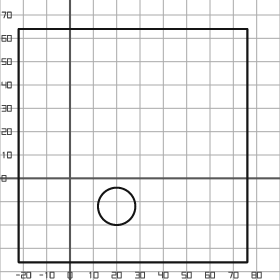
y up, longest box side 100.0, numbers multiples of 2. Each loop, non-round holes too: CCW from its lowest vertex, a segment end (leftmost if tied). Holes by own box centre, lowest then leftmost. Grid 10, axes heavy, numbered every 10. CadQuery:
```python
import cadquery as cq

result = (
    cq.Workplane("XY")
    .moveTo(-22.0, -36.0)
    .lineTo(76.0, -36.0)
    .lineTo(76.0, 64.0)
    .lineTo(-22.0, 64.0)
    .close()
    .moveTo(20.0, -12.0)
    .circle(8.0)
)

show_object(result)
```